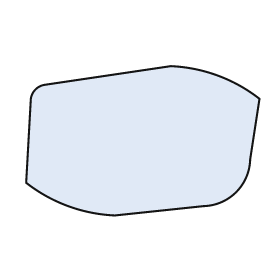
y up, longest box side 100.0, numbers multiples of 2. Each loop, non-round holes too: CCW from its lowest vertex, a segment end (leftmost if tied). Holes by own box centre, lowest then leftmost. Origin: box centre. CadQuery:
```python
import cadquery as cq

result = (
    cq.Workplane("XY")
    .moveTo(-12.0, -32.0)
    .lineTo(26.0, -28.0)
    .threePointArc((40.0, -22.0), (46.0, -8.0))
    .lineTo(50.0, 18.0)
    .threePointArc((32.0, 28.0), (12.0, 32.0))
    .lineTo(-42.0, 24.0)
    .threePointArc((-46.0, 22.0), (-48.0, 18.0))
    .lineTo(-50.0, -18.0)
    .threePointArc((-32.0, -28.0), (-12.0, -32.0))
    .close()
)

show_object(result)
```